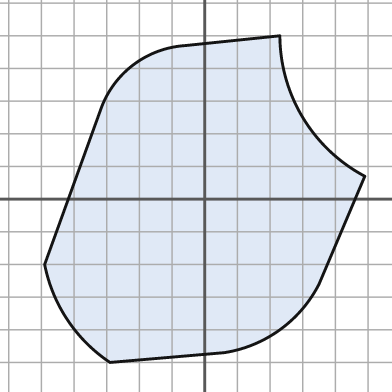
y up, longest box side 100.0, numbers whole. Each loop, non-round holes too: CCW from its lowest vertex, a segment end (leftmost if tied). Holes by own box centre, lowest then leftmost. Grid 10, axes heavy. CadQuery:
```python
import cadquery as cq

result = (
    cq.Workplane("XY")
    .moveTo(-29.0, -50.0)
    .lineTo(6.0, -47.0)
    .threePointArc((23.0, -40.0), (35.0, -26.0))
    .lineTo(49.0, 7.0)
    .threePointArc((30.0, 25.0), (23.0, 50.0))
    .lineTo(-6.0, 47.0)
    .threePointArc((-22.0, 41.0), (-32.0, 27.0))
    .lineTo(-49.0, -20.0)
    .threePointArc((-42.0, -37.0), (-29.0, -50.0))
    .close()
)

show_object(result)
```